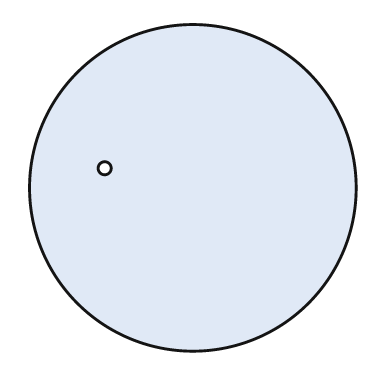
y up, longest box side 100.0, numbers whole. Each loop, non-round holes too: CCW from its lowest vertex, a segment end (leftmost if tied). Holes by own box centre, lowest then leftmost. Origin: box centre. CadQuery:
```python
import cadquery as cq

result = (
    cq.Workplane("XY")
    .moveTo(0.0, 0.0)
    .circle(50.0)
    .moveTo(-27.0, 6.0)
    .circle(2.0)
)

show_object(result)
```